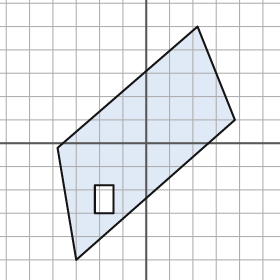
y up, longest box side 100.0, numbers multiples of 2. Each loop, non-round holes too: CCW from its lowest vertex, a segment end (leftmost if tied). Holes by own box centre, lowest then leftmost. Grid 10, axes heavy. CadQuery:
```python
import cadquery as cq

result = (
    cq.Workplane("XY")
    .moveTo(-30.0, -50.0)
    .lineTo(38.0, 10.0)
    .lineTo(22.0, 50.0)
    .lineTo(-38.0, -2.0)
    .close()
    .moveTo(-22.0, -30.0)
    .lineTo(-14.0, -30.0)
    .lineTo(-14.0, -18.0)
    .lineTo(-22.0, -18.0)
    .close()
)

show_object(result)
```